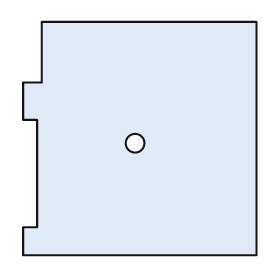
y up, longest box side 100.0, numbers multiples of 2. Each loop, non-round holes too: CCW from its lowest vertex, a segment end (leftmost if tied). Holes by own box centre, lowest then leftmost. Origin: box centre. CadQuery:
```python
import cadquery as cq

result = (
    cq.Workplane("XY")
    .moveTo(-50.0, -50.0)
    .lineTo(50.0, -50.0)
    .lineTo(50.0, 50.0)
    .lineTo(-42.0, 50.0)
    .lineTo(-42.0, 24.0)
    .lineTo(-50.0, 24.0)
    .lineTo(-50.0, 8.0)
    .lineTo(-44.0, 8.0)
    .lineTo(-44.0, -38.0)
    .lineTo(-50.0, -38.0)
    .close()
    .moveTo(-2.0, -2.0)
    .circle(4.0)
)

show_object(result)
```